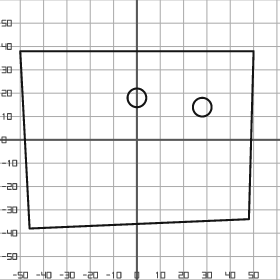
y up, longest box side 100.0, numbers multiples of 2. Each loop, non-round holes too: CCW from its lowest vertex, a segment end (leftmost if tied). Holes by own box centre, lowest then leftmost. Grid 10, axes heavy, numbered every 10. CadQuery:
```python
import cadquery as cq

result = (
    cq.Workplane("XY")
    .moveTo(-46.0, -38.0)
    .lineTo(48.0, -34.0)
    .lineTo(50.0, 38.0)
    .lineTo(-50.0, 38.0)
    .close()
    .moveTo(28.0, 14.0)
    .circle(4.0)
    .moveTo(0.0, 18.0)
    .circle(4.0)
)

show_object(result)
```